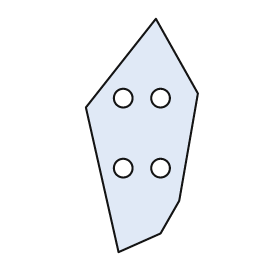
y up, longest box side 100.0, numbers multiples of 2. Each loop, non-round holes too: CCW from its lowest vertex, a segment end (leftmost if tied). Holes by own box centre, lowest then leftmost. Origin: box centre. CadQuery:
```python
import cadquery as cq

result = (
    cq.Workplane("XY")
    .moveTo(-10.0, -50.0)
    .lineTo(8.0, -42.0)
    .lineTo(16.0, -28.0)
    .lineTo(24.0, 18.0)
    .lineTo(6.0, 50.0)
    .lineTo(-24.0, 12.0)
    .close()
    .moveTo(-8.0, -14.0)
    .circle(4.0)
    .moveTo(8.0, -14.0)
    .circle(4.0)
    .moveTo(-8.0, 16.0)
    .circle(4.0)
    .moveTo(8.0, 16.0)
    .circle(4.0)
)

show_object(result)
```